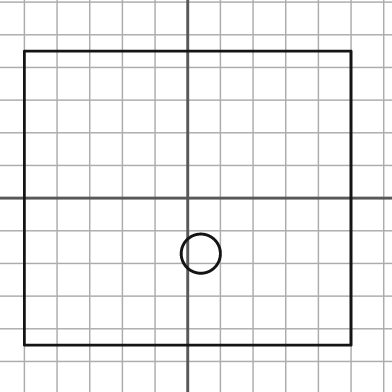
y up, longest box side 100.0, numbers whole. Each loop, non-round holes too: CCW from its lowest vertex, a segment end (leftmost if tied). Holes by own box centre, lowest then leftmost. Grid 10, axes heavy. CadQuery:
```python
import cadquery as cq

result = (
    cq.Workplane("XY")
    .moveTo(-50.0, -45.0)
    .lineTo(50.0, -45.0)
    .lineTo(50.0, 45.0)
    .lineTo(-50.0, 45.0)
    .close()
    .moveTo(4.0, -17.0)
    .circle(6.0)
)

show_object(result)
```